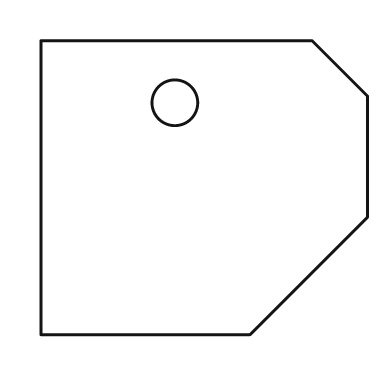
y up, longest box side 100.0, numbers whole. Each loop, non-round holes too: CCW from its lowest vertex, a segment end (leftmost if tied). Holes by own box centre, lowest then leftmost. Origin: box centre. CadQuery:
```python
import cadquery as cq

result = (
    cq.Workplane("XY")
    .moveTo(-50.0, -45.0)
    .lineTo(14.0, -45.0)
    .lineTo(50.0, -9.0)
    .lineTo(50.0, 28.0)
    .lineTo(33.0, 45.0)
    .lineTo(-50.0, 45.0)
    .close()
    .moveTo(-9.0, 26.0)
    .circle(7.0)
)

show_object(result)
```